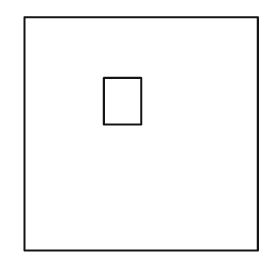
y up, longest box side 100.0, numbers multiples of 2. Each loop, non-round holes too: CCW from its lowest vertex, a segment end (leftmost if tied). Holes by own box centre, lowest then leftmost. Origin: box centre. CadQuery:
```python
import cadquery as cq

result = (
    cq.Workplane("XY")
    .moveTo(-50.0, -50.0)
    .lineTo(50.0, -50.0)
    .lineTo(50.0, 50.0)
    .lineTo(-50.0, 50.0)
    .close()
    .moveTo(-16.0, 4.0)
    .lineTo(0.0, 4.0)
    .lineTo(0.0, 24.0)
    .lineTo(-16.0, 24.0)
    .close()
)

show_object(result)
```